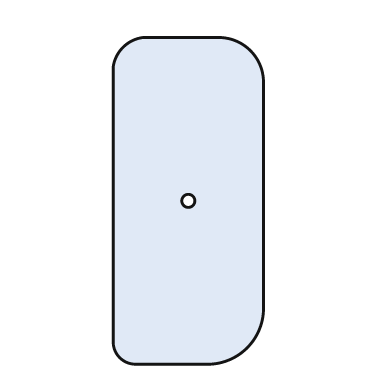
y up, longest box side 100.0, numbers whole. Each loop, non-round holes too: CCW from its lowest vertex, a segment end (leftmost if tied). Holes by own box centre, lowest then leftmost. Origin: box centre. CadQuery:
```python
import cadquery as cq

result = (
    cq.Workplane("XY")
    .moveTo(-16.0, -50.0)
    .lineTo(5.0, -50.0)
    .threePointArc((18.0, -45.0), (23.0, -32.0))
    .lineTo(23.0, 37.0)
    .threePointArc((19.0, 46.0), (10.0, 50.0))
    .lineTo(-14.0, 50.0)
    .threePointArc((-20.0, 47.0), (-23.0, 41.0))
    .lineTo(-23.0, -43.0)
    .threePointArc((-21.0, -48.0), (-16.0, -50.0))
    .close()
    .moveTo(0.0, 0.0)
    .circle(2.0)
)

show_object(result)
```